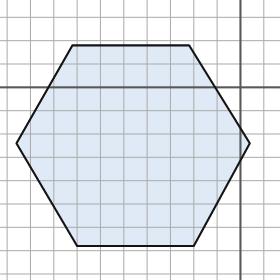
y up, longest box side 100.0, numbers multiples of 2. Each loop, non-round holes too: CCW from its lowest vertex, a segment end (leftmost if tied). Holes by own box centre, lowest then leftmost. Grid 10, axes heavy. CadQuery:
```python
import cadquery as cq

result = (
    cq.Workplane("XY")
    .moveTo(-70.0, -68.0)
    .lineTo(-20.0, -68.0)
    .lineTo(4.0, -24.0)
    .lineTo(-22.0, 18.0)
    .lineTo(-72.0, 18.0)
    .lineTo(-96.0, -24.0)
    .close()
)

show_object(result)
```